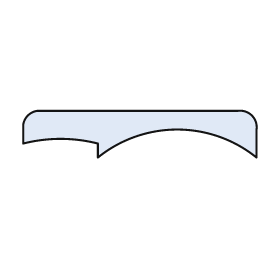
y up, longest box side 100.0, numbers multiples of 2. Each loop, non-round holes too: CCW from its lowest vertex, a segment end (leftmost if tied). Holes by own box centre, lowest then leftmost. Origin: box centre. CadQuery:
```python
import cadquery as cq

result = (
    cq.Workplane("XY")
    .moveTo(-18.0, -10.0)
    .threePointArc((16.0, 2.0), (50.0, -10.0))
    .lineTo(50.0, 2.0)
    .threePointArc((48.0, 8.0), (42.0, 10.0))
    .lineTo(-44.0, 10.0)
    .threePointArc((-48.0, 8.0), (-50.0, 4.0))
    .lineTo(-50.0, -4.0)
    .threePointArc((-34.0, -2.0), (-18.0, -4.0))
    .close()
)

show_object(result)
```